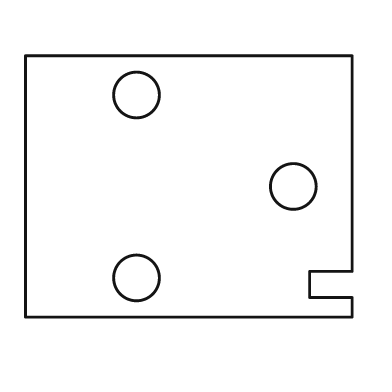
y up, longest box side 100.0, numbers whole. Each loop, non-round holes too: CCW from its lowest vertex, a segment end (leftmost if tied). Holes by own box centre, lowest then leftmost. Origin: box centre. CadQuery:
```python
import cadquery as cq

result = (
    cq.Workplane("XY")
    .moveTo(-50.0, -40.0)
    .lineTo(50.0, -40.0)
    .lineTo(50.0, -34.0)
    .lineTo(37.0, -34.0)
    .lineTo(37.0, -26.0)
    .lineTo(50.0, -26.0)
    .lineTo(50.0, 40.0)
    .lineTo(-50.0, 40.0)
    .close()
    .moveTo(-16.0, -28.0)
    .circle(7.0)
    .moveTo(32.0, 0.0)
    .circle(7.0)
    .moveTo(-16.0, 28.0)
    .circle(7.0)
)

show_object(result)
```